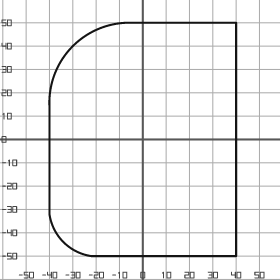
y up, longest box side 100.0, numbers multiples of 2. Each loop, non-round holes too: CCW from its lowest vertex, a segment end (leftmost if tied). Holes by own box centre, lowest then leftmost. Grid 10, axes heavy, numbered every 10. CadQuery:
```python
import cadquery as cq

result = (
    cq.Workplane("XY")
    .moveTo(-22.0, -50.0)
    .lineTo(40.0, -50.0)
    .lineTo(40.0, 50.0)
    .lineTo(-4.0, 50.0)
    .threePointArc((-30.0, 40.0), (-40.0, 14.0))
    .lineTo(-40.0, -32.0)
    .threePointArc((-34.0, -44.0), (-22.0, -50.0))
    .close()
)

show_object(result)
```